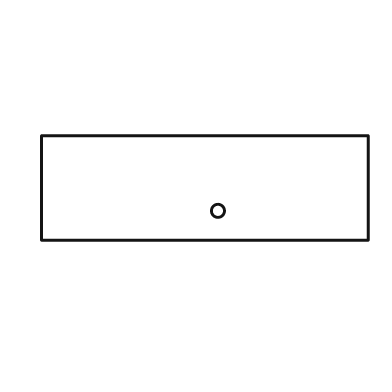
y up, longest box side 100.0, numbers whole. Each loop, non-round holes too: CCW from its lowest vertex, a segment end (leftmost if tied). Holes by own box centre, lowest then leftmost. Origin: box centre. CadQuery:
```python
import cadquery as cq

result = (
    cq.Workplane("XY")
    .moveTo(-50.0, -16.0)
    .lineTo(50.0, -16.0)
    .lineTo(50.0, 16.0)
    .lineTo(-50.0, 16.0)
    .close()
    .moveTo(4.0, -7.0)
    .circle(2.0)
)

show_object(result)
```